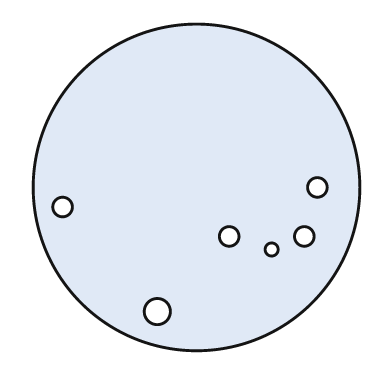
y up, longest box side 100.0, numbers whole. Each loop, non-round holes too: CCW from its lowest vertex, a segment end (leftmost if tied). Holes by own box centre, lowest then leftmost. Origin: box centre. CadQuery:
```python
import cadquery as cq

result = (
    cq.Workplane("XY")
    .moveTo(0.0, 0.0)
    .circle(50.0)
    .moveTo(-12.0, -38.0)
    .circle(4.0)
    .moveTo(23.0, -19.0)
    .circle(2.0)
    .moveTo(10.0, -15.0)
    .circle(3.0)
    .moveTo(33.0, -15.0)
    .circle(3.0)
    .moveTo(-41.0, -6.0)
    .circle(3.0)
    .moveTo(37.0, 0.0)
    .circle(3.0)
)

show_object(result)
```